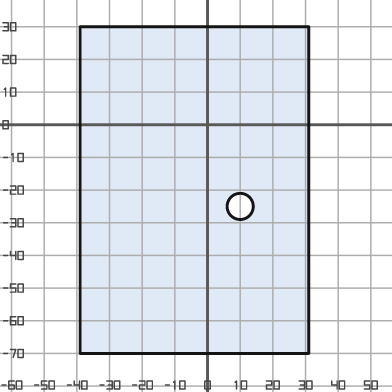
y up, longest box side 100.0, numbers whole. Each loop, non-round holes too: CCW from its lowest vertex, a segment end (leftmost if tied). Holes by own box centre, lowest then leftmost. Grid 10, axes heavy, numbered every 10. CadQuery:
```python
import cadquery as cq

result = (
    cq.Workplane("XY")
    .moveTo(-39.0, -70.0)
    .lineTo(31.0, -70.0)
    .lineTo(31.0, 30.0)
    .lineTo(-39.0, 30.0)
    .close()
    .moveTo(10.0, -25.0)
    .circle(4.0)
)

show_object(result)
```